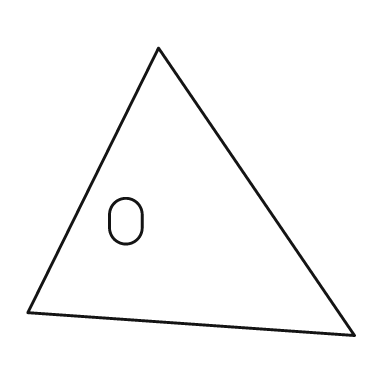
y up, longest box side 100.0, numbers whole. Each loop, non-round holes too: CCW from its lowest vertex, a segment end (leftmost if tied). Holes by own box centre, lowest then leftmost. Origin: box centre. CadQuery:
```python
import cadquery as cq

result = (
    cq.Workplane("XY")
    .moveTo(50.0, -44.0)
    .lineTo(-10.0, 44.0)
    .lineTo(-50.0, -37.0)
    .close()
    .moveTo(-25.0, -11.0)
    .threePointArc((-20.0, -16.0), (-15.0, -11.0))
    .lineTo(-15.0, -7.0)
    .threePointArc((-20.0, -2.0), (-25.0, -7.0))
    .close()
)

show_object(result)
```